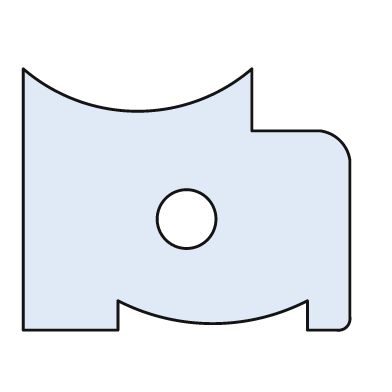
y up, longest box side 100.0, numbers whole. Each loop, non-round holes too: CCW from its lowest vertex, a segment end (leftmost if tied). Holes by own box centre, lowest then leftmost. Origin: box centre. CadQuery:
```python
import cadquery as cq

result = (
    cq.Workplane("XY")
    .moveTo(-50.0, -40.0)
    .lineTo(-21.0, -40.0)
    .lineTo(-21.0, -31.0)
    .threePointArc((8.0, -38.0), (37.0, -31.0))
    .lineTo(37.0, -40.0)
    .lineTo(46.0, -40.0)
    .threePointArc((49.0, -39.0), (50.0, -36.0))
    .lineTo(50.0, 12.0)
    .threePointArc((47.0, 18.0), (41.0, 21.0))
    .lineTo(20.0, 21.0)
    .lineTo(20.0, 40.0)
    .threePointArc((-15.0, 27.0), (-50.0, 40.0))
    .close()
    .moveTo(0.0, -6.0)
    .circle(9.0)
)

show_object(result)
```